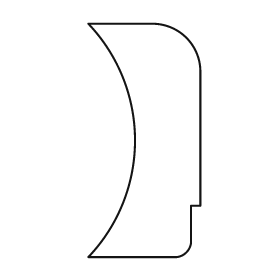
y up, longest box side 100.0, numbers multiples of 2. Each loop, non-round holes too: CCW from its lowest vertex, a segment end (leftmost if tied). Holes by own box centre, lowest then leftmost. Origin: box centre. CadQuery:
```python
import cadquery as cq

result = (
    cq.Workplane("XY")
    .moveTo(-24.0, -50.0)
    .lineTo(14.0, -50.0)
    .threePointArc((18.0, -48.0), (20.0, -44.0))
    .lineTo(20.0, -28.0)
    .lineTo(24.0, -28.0)
    .lineTo(24.0, 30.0)
    .threePointArc((18.0, 44.0), (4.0, 50.0))
    .lineTo(-24.0, 50.0)
    .threePointArc((-4.0, 0.0), (-24.0, -50.0))
    .close()
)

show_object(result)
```